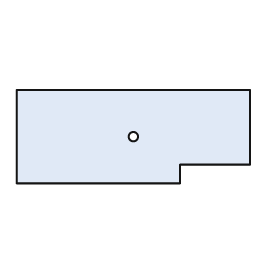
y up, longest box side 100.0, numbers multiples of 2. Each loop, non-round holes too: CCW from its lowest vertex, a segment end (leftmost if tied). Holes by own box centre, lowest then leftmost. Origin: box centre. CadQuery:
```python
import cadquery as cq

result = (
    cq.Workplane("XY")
    .moveTo(-50.0, -20.0)
    .lineTo(20.0, -20.0)
    .lineTo(20.0, -12.0)
    .lineTo(50.0, -12.0)
    .lineTo(50.0, 20.0)
    .lineTo(-50.0, 20.0)
    .close()
    .moveTo(0.0, 0.0)
    .circle(2.0)
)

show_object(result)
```